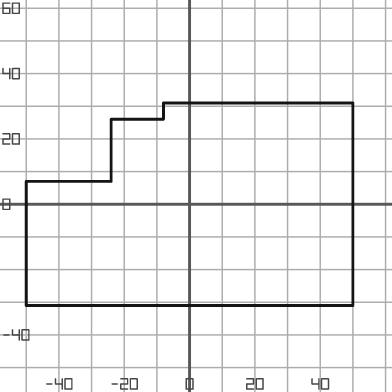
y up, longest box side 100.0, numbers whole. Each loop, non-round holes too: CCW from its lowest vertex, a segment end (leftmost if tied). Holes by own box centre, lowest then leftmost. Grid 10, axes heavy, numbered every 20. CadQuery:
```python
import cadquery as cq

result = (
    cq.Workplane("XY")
    .moveTo(-50.0, -31.0)
    .lineTo(50.0, -31.0)
    .lineTo(50.0, 31.0)
    .lineTo(-8.0, 31.0)
    .lineTo(-8.0, 26.0)
    .lineTo(-24.0, 26.0)
    .lineTo(-24.0, 7.0)
    .lineTo(-50.0, 7.0)
    .close()
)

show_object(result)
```